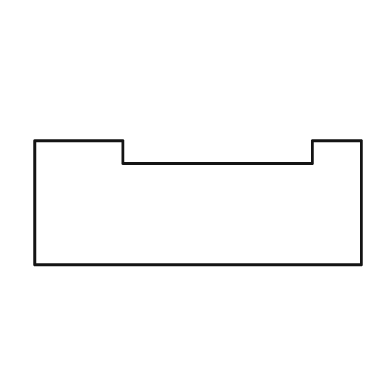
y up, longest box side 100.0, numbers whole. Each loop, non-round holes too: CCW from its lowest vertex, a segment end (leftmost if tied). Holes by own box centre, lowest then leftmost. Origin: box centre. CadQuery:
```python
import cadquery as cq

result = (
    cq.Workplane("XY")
    .moveTo(-50.0, -19.0)
    .lineTo(50.0, -19.0)
    .lineTo(50.0, 19.0)
    .lineTo(35.0, 19.0)
    .lineTo(35.0, 12.0)
    .lineTo(-23.0, 12.0)
    .lineTo(-23.0, 19.0)
    .lineTo(-50.0, 19.0)
    .close()
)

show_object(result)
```